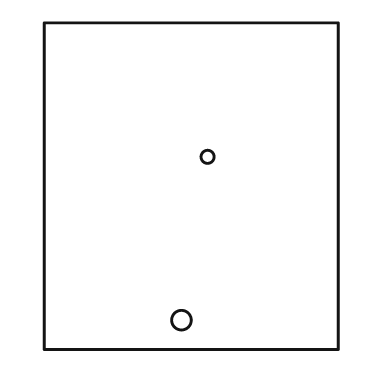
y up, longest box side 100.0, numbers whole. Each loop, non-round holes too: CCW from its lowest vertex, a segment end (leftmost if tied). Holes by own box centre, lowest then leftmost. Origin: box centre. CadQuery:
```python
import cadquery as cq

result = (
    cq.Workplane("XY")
    .moveTo(-45.0, -50.0)
    .lineTo(45.0, -50.0)
    .lineTo(45.0, 50.0)
    .lineTo(-45.0, 50.0)
    .close()
    .moveTo(-3.0, -41.0)
    .circle(3.0)
    .moveTo(5.0, 9.0)
    .circle(2.0)
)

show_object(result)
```